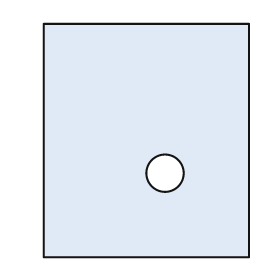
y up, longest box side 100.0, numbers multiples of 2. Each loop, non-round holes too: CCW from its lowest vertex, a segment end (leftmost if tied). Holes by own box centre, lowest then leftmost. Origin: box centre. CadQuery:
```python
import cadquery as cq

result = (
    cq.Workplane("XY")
    .moveTo(-44.0, -50.0)
    .lineTo(44.0, -50.0)
    .lineTo(44.0, 50.0)
    .lineTo(-44.0, 50.0)
    .close()
    .moveTo(8.0, -14.0)
    .circle(8.0)
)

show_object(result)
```